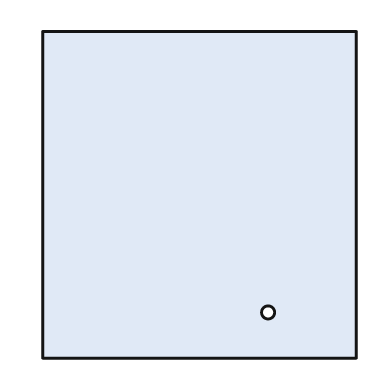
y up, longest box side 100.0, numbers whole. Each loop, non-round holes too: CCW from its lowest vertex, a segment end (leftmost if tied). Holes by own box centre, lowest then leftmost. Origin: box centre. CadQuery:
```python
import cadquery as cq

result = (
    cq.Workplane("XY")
    .moveTo(-48.0, -50.0)
    .lineTo(48.0, -50.0)
    .lineTo(48.0, 50.0)
    .lineTo(-48.0, 50.0)
    .close()
    .moveTo(21.0, -36.0)
    .circle(2.0)
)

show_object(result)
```